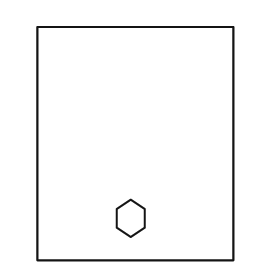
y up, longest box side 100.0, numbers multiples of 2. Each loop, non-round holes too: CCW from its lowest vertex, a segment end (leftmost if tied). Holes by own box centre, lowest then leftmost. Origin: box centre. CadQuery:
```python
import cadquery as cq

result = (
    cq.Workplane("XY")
    .moveTo(-42.0, -50.0)
    .lineTo(42.0, -50.0)
    .lineTo(42.0, 50.0)
    .lineTo(-42.0, 50.0)
    .close()
    .moveTo(-2.0, -40.0)
    .lineTo(4.0, -36.0)
    .lineTo(4.0, -28.0)
    .lineTo(-2.0, -24.0)
    .lineTo(-8.0, -28.0)
    .lineTo(-8.0, -36.0)
    .close()
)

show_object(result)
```